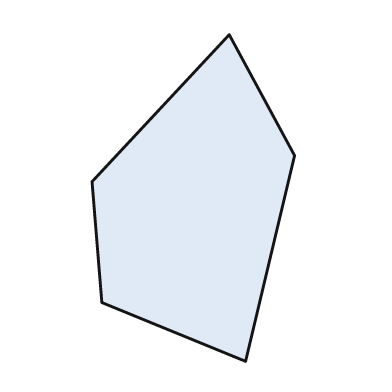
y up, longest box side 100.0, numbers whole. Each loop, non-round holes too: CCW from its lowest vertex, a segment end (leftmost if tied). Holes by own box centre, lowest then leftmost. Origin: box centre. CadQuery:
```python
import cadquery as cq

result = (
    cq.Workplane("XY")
    .moveTo(16.0, -50.0)
    .lineTo(31.0, 13.0)
    .lineTo(11.0, 50.0)
    .lineTo(-31.0, 5.0)
    .lineTo(-28.0, -32.0)
    .close()
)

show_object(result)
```